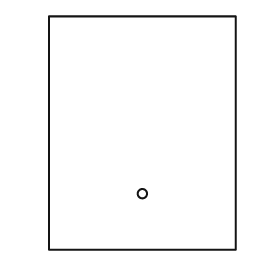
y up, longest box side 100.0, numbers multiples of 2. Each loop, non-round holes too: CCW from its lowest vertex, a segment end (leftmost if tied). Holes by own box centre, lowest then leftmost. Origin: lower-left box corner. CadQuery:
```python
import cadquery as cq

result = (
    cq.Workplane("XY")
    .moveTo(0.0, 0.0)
    .lineTo(80.0, 0.0)
    .lineTo(80.0, 100.0)
    .lineTo(0.0, 100.0)
    .close()
    .moveTo(40.0, 24.0)
    .circle(2.0)
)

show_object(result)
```